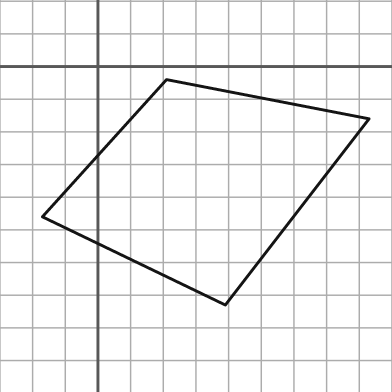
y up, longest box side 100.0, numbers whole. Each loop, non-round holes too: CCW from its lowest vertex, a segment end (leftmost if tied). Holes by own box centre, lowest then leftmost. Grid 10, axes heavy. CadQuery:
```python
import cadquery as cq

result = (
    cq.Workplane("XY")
    .moveTo(39.0, -73.0)
    .lineTo(83.0, -16.0)
    .lineTo(21.0, -4.0)
    .lineTo(-17.0, -46.0)
    .close()
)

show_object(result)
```